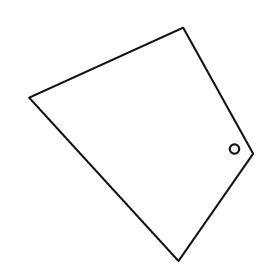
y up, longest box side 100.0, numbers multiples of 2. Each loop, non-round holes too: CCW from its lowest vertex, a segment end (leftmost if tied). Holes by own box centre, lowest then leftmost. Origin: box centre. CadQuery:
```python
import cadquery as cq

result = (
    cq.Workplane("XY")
    .moveTo(16.0, -50.0)
    .lineTo(48.0, -4.0)
    .lineTo(18.0, 50.0)
    .lineTo(-48.0, 20.0)
    .close()
    .moveTo(40.0, -2.0)
    .circle(2.0)
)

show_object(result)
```